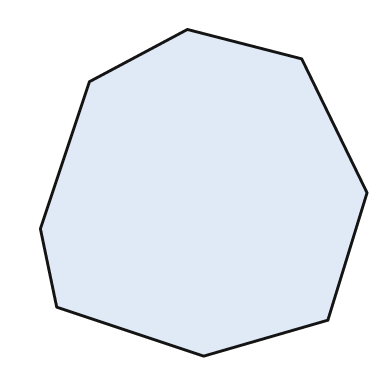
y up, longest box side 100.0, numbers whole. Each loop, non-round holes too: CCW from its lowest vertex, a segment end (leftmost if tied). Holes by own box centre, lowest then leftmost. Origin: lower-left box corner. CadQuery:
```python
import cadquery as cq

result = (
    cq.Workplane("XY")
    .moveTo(50.0, 0.0)
    .lineTo(88.0, 11.0)
    .lineTo(100.0, 50.0)
    .lineTo(80.0, 91.0)
    .lineTo(45.0, 100.0)
    .lineTo(15.0, 84.0)
    .lineTo(0.0, 39.0)
    .lineTo(5.0, 15.0)
    .close()
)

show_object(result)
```